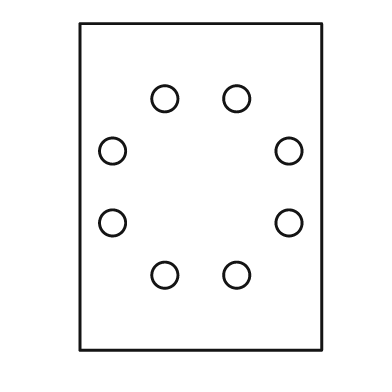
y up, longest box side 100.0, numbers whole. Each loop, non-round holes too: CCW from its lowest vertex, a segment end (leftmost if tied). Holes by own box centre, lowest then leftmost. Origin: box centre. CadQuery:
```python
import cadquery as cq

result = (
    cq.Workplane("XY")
    .moveTo(-37.0, -50.0)
    .lineTo(37.0, -50.0)
    .lineTo(37.0, 50.0)
    .lineTo(-37.0, 50.0)
    .close()
    .moveTo(-11.0, -27.0)
    .circle(4.0)
    .moveTo(11.0, -27.0)
    .circle(4.0)
    .moveTo(-27.0, -11.0)
    .circle(4.0)
    .moveTo(27.0, -11.0)
    .circle(4.0)
    .moveTo(-27.0, 11.0)
    .circle(4.0)
    .moveTo(27.0, 11.0)
    .circle(4.0)
    .moveTo(-11.0, 27.0)
    .circle(4.0)
    .moveTo(11.0, 27.0)
    .circle(4.0)
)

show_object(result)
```